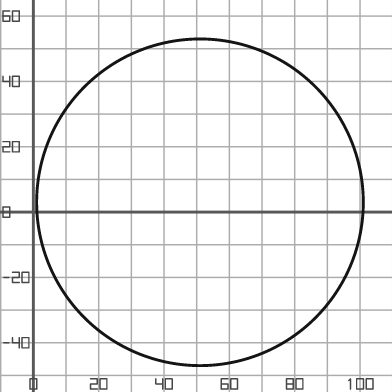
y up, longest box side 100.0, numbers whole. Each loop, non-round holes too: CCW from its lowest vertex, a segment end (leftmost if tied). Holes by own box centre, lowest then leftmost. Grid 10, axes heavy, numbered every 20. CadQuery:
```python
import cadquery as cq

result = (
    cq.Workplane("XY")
    .moveTo(51.0, 3.0)
    .circle(50.0)
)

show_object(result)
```